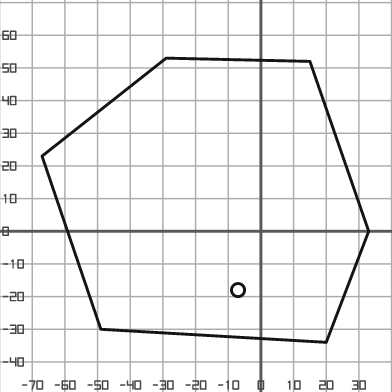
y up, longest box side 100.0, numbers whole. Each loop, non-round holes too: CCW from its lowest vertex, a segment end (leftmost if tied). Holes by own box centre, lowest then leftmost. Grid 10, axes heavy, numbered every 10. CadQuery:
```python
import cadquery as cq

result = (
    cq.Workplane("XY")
    .moveTo(20.0, -34.0)
    .lineTo(33.0, 0.0)
    .lineTo(15.0, 52.0)
    .lineTo(-29.0, 53.0)
    .lineTo(-67.0, 23.0)
    .lineTo(-49.0, -30.0)
    .close()
    .moveTo(-7.0, -18.0)
    .circle(2.0)
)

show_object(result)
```